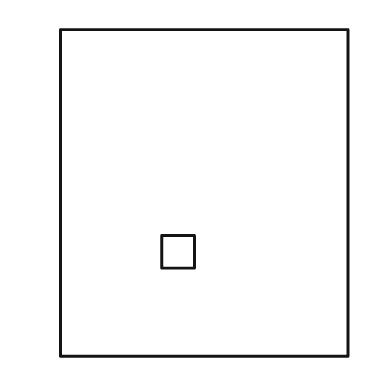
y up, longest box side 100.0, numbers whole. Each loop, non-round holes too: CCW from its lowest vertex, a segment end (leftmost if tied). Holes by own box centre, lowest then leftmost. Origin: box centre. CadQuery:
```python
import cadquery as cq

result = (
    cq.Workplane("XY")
    .moveTo(-44.0, -50.0)
    .lineTo(44.0, -50.0)
    .lineTo(44.0, 50.0)
    .lineTo(-44.0, 50.0)
    .close()
    .moveTo(-13.0, -23.0)
    .lineTo(-3.0, -23.0)
    .lineTo(-3.0, -13.0)
    .lineTo(-13.0, -13.0)
    .close()
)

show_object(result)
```